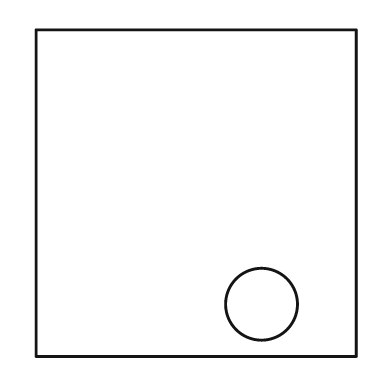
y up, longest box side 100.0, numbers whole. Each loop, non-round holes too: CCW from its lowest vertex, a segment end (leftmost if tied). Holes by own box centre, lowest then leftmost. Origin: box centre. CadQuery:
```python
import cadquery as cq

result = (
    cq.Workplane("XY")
    .moveTo(-49.0, -50.0)
    .lineTo(49.0, -50.0)
    .lineTo(49.0, 50.0)
    .lineTo(-49.0, 50.0)
    .close()
    .moveTo(20.0, -34.0)
    .circle(11.0)
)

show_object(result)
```